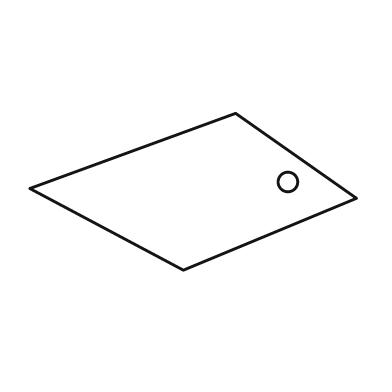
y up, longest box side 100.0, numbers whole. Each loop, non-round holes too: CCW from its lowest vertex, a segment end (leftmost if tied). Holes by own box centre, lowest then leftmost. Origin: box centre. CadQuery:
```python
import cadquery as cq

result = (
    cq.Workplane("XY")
    .moveTo(-3.0, -24.0)
    .lineTo(50.0, -2.0)
    .lineTo(13.0, 24.0)
    .lineTo(-50.0, 1.0)
    .close()
    .moveTo(29.0, 3.0)
    .circle(3.0)
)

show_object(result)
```